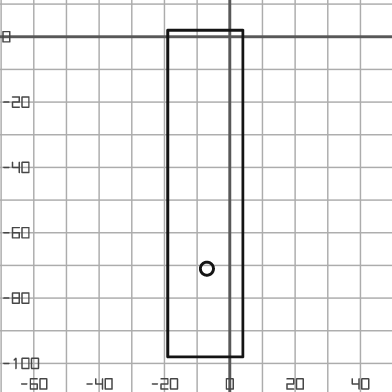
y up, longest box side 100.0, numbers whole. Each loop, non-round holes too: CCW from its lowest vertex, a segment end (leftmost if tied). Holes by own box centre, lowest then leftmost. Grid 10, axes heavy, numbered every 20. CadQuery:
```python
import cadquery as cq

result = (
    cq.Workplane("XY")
    .moveTo(-19.0, -98.0)
    .lineTo(4.0, -98.0)
    .lineTo(4.0, 2.0)
    .lineTo(-19.0, 2.0)
    .close()
    .moveTo(-7.0, -71.0)
    .circle(2.0)
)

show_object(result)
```